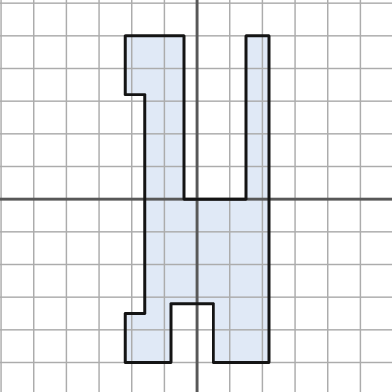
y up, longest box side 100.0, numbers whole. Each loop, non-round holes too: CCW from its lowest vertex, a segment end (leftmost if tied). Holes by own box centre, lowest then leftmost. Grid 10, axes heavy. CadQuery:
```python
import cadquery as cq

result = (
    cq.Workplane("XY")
    .moveTo(-22.0, -50.0)
    .lineTo(-8.0, -50.0)
    .lineTo(-8.0, -32.0)
    .lineTo(5.0, -32.0)
    .lineTo(5.0, -50.0)
    .lineTo(22.0, -50.0)
    .lineTo(22.0, 50.0)
    .lineTo(15.0, 50.0)
    .lineTo(15.0, 0.0)
    .lineTo(-4.0, 0.0)
    .lineTo(-4.0, 50.0)
    .lineTo(-22.0, 50.0)
    .lineTo(-22.0, 32.0)
    .lineTo(-16.0, 32.0)
    .lineTo(-16.0, -35.0)
    .lineTo(-22.0, -35.0)
    .close()
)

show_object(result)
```